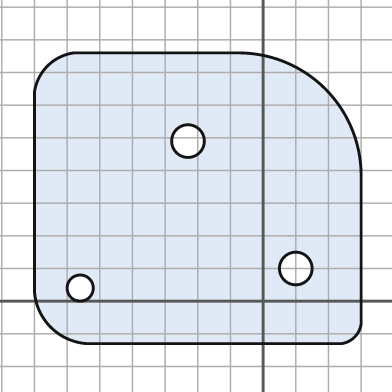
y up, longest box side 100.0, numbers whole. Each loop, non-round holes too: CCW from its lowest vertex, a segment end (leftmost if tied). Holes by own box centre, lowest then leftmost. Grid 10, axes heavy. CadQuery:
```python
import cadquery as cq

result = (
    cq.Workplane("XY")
    .moveTo(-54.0, -13.0)
    .lineTo(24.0, -13.0)
    .threePointArc((28.0, -11.0), (30.0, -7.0))
    .lineTo(30.0, 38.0)
    .threePointArc((19.0, 65.0), (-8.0, 76.0))
    .lineTo(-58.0, 76.0)
    .threePointArc((-66.0, 72.0), (-70.0, 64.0))
    .lineTo(-70.0, 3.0)
    .threePointArc((-65.0, -8.0), (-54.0, -13.0))
    .close()
    .moveTo(-56.0, 4.0)
    .circle(4.0)
    .moveTo(10.0, 10.0)
    .circle(5.0)
    .moveTo(-23.0, 49.0)
    .circle(5.0)
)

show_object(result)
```